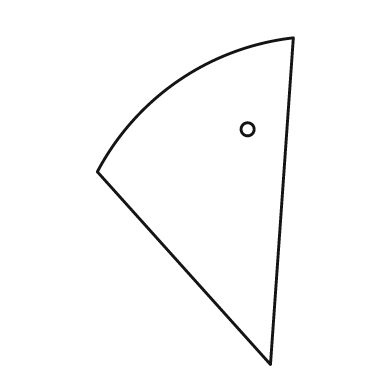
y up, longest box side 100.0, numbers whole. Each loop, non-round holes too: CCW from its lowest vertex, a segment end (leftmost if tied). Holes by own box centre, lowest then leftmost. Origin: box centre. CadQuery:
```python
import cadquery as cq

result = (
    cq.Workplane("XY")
    .moveTo(23.0, -50.0)
    .lineTo(30.0, 50.0)
    .threePointArc((-5.0, 37.0), (-30.0, 9.0))
    .close()
    .moveTo(16.0, 22.0)
    .circle(2.0)
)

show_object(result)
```